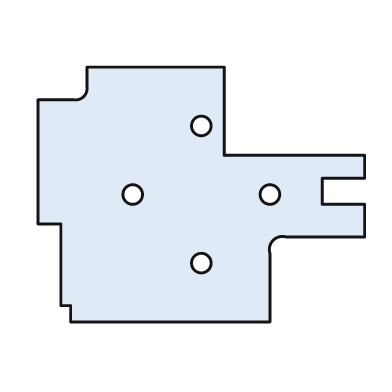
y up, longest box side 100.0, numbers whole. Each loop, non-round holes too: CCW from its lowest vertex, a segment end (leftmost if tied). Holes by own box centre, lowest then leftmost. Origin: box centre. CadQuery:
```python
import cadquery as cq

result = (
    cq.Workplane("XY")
    .moveTo(-40.0, -39.0)
    .lineTo(21.0, -39.0)
    .lineTo(21.0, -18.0)
    .threePointArc((22.0, -14.0), (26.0, -13.0))
    .lineTo(50.0, -13.0)
    .lineTo(50.0, -3.0)
    .lineTo(37.0, -3.0)
    .lineTo(37.0, 5.0)
    .lineTo(50.0, 5.0)
    .lineTo(50.0, 12.0)
    .lineTo(7.0, 12.0)
    .lineTo(7.0, 39.0)
    .lineTo(-35.0, 39.0)
    .lineTo(-35.0, 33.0)
    .threePointArc((-36.0, 30.0), (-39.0, 29.0))
    .lineTo(-50.0, 29.0)
    .lineTo(-50.0, -9.0)
    .lineTo(-43.0, -9.0)
    .lineTo(-43.0, -34.0)
    .lineTo(-40.0, -34.0)
    .close()
    .moveTo(0.0, -21.0)
    .circle(3.0)
    .moveTo(-21.0, 0.0)
    .circle(3.0)
    .moveTo(21.0, 0.0)
    .circle(3.0)
    .moveTo(0.0, 21.0)
    .circle(3.0)
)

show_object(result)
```